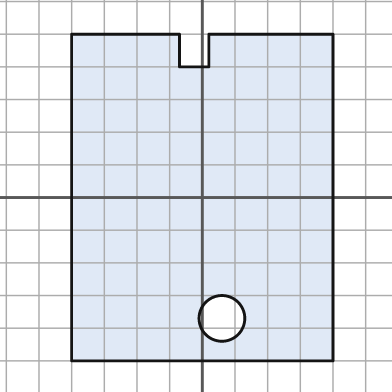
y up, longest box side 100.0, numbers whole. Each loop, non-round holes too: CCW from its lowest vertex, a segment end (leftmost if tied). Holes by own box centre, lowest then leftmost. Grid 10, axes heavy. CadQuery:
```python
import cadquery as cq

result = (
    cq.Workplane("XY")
    .moveTo(-40.0, -50.0)
    .lineTo(40.0, -50.0)
    .lineTo(40.0, 50.0)
    .lineTo(2.0, 50.0)
    .lineTo(2.0, 40.0)
    .lineTo(-7.0, 40.0)
    .lineTo(-7.0, 50.0)
    .lineTo(-40.0, 50.0)
    .close()
    .moveTo(6.0, -37.0)
    .circle(7.0)
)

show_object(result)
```